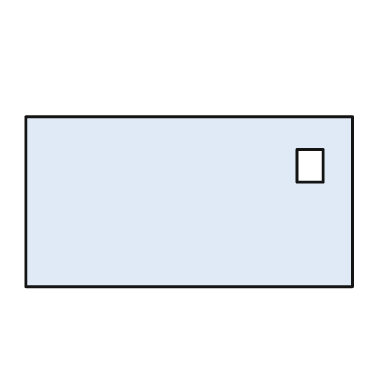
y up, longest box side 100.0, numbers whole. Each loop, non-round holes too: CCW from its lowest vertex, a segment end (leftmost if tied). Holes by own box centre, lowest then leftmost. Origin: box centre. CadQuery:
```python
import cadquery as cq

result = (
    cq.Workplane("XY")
    .moveTo(-50.0, -26.0)
    .lineTo(50.0, -26.0)
    .lineTo(50.0, 26.0)
    .lineTo(-50.0, 26.0)
    .close()
    .moveTo(33.0, 6.0)
    .lineTo(41.0, 6.0)
    .lineTo(41.0, 16.0)
    .lineTo(33.0, 16.0)
    .close()
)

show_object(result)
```